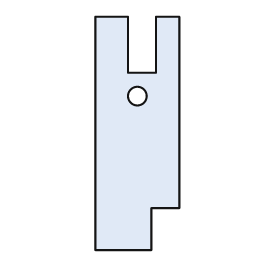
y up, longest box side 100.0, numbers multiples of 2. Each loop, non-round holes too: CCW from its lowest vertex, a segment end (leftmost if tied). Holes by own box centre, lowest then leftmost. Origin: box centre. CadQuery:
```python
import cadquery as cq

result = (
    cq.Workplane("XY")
    .moveTo(-18.0, -50.0)
    .lineTo(6.0, -50.0)
    .lineTo(6.0, -32.0)
    .lineTo(18.0, -32.0)
    .lineTo(18.0, 50.0)
    .lineTo(8.0, 50.0)
    .lineTo(8.0, 26.0)
    .lineTo(-4.0, 26.0)
    .lineTo(-4.0, 50.0)
    .lineTo(-18.0, 50.0)
    .close()
    .moveTo(0.0, 16.0)
    .circle(4.0)
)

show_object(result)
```